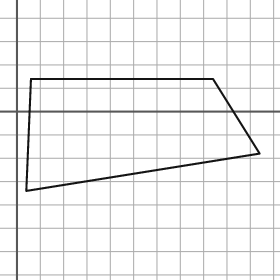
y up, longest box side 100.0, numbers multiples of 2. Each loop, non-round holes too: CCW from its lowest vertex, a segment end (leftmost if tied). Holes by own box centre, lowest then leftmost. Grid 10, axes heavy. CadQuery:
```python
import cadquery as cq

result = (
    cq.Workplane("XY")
    .moveTo(4.0, -34.0)
    .lineTo(104.0, -18.0)
    .lineTo(84.0, 14.0)
    .lineTo(6.0, 14.0)
    .close()
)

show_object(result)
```